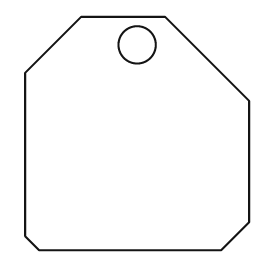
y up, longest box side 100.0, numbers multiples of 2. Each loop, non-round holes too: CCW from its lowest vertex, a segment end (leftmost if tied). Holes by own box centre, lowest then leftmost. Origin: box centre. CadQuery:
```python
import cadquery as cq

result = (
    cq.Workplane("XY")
    .moveTo(-42.0, -50.0)
    .lineTo(36.0, -50.0)
    .lineTo(48.0, -38.0)
    .lineTo(48.0, 14.0)
    .lineTo(12.0, 50.0)
    .lineTo(-24.0, 50.0)
    .lineTo(-48.0, 26.0)
    .lineTo(-48.0, -44.0)
    .close()
    .moveTo(0.0, 38.0)
    .circle(8.0)
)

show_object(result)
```